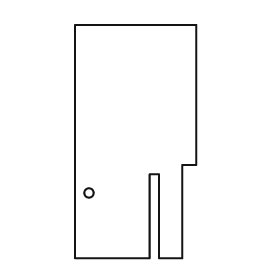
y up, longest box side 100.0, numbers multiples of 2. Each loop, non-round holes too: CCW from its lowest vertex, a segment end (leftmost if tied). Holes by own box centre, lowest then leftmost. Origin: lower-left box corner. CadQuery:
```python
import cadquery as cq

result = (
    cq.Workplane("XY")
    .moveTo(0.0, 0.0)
    .lineTo(32.0, 0.0)
    .lineTo(32.0, 36.0)
    .lineTo(36.0, 36.0)
    .lineTo(36.0, 0.0)
    .lineTo(46.0, 0.0)
    .lineTo(46.0, 40.0)
    .lineTo(52.0, 40.0)
    .lineTo(52.0, 100.0)
    .lineTo(0.0, 100.0)
    .close()
    .moveTo(6.0, 28.0)
    .circle(2.0)
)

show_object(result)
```